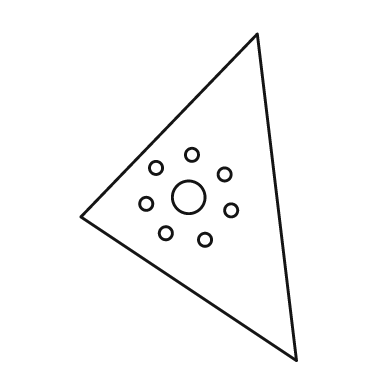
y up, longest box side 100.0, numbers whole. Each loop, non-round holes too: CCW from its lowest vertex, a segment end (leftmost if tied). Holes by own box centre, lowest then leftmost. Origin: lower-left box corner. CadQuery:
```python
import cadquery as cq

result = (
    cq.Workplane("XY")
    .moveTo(66.0, 0.0)
    .lineTo(54.0, 100.0)
    .lineTo(0.0, 44.0)
    .close()
    .moveTo(38.0, 37.0)
    .circle(2.0)
    .moveTo(26.0, 39.0)
    .circle(2.0)
    .moveTo(46.0, 46.0)
    .circle(2.0)
    .moveTo(20.0, 48.0)
    .circle(2.0)
    .moveTo(33.0, 50.0)
    .circle(5.0)
    .moveTo(44.0, 57.0)
    .circle(2.0)
    .moveTo(23.0, 59.0)
    .circle(2.0)
    .moveTo(34.0, 63.0)
    .circle(2.0)
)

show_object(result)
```